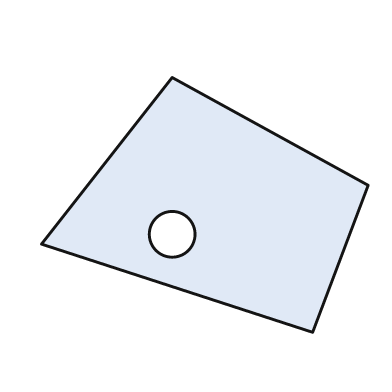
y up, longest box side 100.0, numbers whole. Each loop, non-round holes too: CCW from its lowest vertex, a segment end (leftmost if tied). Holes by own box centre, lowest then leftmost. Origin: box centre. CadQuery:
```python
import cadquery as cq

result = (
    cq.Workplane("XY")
    .moveTo(33.0, -39.0)
    .lineTo(50.0, 6.0)
    .lineTo(-10.0, 39.0)
    .lineTo(-50.0, -12.0)
    .close()
    .moveTo(-10.0, -9.0)
    .circle(7.0)
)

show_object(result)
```